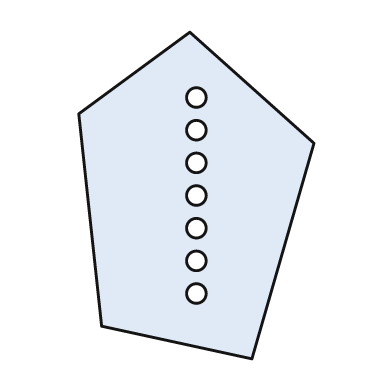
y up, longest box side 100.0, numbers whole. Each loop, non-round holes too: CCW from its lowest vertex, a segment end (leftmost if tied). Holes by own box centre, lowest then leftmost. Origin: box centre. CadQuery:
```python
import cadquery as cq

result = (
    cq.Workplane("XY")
    .moveTo(17.0, -50.0)
    .lineTo(36.0, 16.0)
    .lineTo(-2.0, 50.0)
    .lineTo(-36.0, 25.0)
    .lineTo(-29.0, -40.0)
    .close()
    .moveTo(0.0, -30.0)
    .circle(3.0)
    .moveTo(0.0, -20.0)
    .circle(3.0)
    .moveTo(0.0, -10.0)
    .circle(3.0)
    .moveTo(0.0, 0.0)
    .circle(3.0)
    .moveTo(0.0, 10.0)
    .circle(3.0)
    .moveTo(0.0, 20.0)
    .circle(3.0)
    .moveTo(0.0, 30.0)
    .circle(3.0)
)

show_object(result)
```